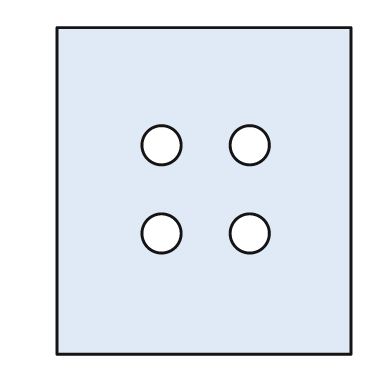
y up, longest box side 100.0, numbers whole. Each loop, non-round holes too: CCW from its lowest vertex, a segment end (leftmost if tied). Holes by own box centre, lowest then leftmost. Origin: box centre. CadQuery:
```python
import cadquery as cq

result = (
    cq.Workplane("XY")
    .moveTo(-45.0, -50.0)
    .lineTo(45.0, -50.0)
    .lineTo(45.0, 50.0)
    .lineTo(-45.0, 50.0)
    .close()
    .moveTo(-13.0, -13.0)
    .circle(6.0)
    .moveTo(14.0, -13.0)
    .circle(6.0)
    .moveTo(-13.0, 14.0)
    .circle(6.0)
    .moveTo(14.0, 14.0)
    .circle(6.0)
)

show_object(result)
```